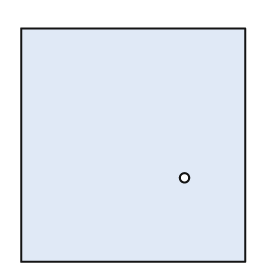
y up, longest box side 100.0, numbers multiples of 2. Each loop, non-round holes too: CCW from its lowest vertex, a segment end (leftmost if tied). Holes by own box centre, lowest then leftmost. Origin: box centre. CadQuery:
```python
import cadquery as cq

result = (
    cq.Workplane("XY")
    .moveTo(-48.0, -50.0)
    .lineTo(48.0, -50.0)
    .lineTo(48.0, 50.0)
    .lineTo(-48.0, 50.0)
    .close()
    .moveTo(22.0, -14.0)
    .circle(2.0)
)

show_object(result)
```